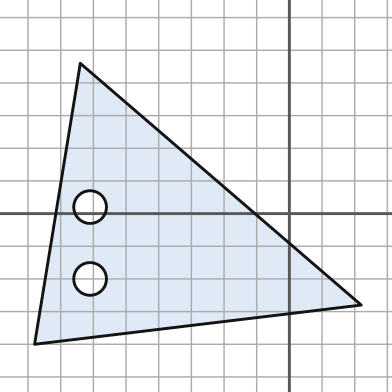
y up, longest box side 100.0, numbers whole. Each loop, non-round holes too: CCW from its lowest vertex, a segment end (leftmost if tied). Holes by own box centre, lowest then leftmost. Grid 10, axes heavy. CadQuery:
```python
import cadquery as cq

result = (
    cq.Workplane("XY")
    .moveTo(-78.0, -40.0)
    .lineTo(22.0, -28.0)
    .lineTo(-64.0, 46.0)
    .close()
    .moveTo(-61.0, -20.0)
    .circle(5.0)
    .moveTo(-61.0, 2.0)
    .circle(5.0)
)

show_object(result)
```